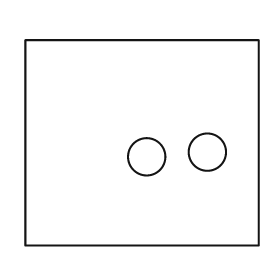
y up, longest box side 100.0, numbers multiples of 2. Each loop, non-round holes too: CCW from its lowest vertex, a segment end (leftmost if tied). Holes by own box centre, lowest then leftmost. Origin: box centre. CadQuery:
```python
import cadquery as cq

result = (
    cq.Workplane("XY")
    .moveTo(-50.0, -44.0)
    .lineTo(50.0, -44.0)
    .lineTo(50.0, 44.0)
    .lineTo(-50.0, 44.0)
    .close()
    .moveTo(2.0, -6.0)
    .circle(8.0)
    .moveTo(28.0, -4.0)
    .circle(8.0)
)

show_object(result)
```